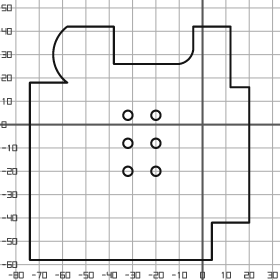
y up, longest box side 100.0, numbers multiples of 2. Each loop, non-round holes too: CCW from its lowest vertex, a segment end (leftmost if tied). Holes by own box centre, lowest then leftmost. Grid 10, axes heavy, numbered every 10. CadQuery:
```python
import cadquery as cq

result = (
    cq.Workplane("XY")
    .moveTo(-74.0, -58.0)
    .lineTo(4.0, -58.0)
    .lineTo(4.0, -42.0)
    .lineTo(20.0, -42.0)
    .lineTo(20.0, 16.0)
    .lineTo(12.0, 16.0)
    .lineTo(12.0, 42.0)
    .lineTo(-4.0, 42.0)
    .lineTo(-4.0, 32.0)
    .threePointArc((-6.0, 28.0), (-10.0, 26.0))
    .lineTo(-38.0, 26.0)
    .lineTo(-38.0, 42.0)
    .lineTo(-58.0, 42.0)
    .threePointArc((-64.0, 30.0), (-58.0, 18.0))
    .lineTo(-74.0, 18.0)
    .close()
    .moveTo(-32.0, -20.0)
    .circle(2.0)
    .moveTo(-20.0, -20.0)
    .circle(2.0)
    .moveTo(-32.0, -8.0)
    .circle(2.0)
    .moveTo(-20.0, -8.0)
    .circle(2.0)
    .moveTo(-32.0, 4.0)
    .circle(2.0)
    .moveTo(-20.0, 4.0)
    .circle(2.0)
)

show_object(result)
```